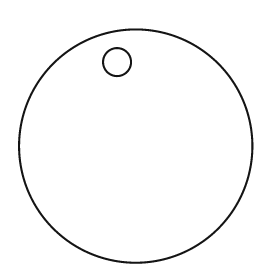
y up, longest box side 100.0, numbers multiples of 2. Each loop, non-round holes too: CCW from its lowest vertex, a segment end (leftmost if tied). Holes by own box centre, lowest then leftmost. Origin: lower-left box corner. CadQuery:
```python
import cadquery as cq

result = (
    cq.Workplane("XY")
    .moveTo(50.0, 50.0)
    .circle(50.0)
    .moveTo(42.0, 86.0)
    .circle(6.0)
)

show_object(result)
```